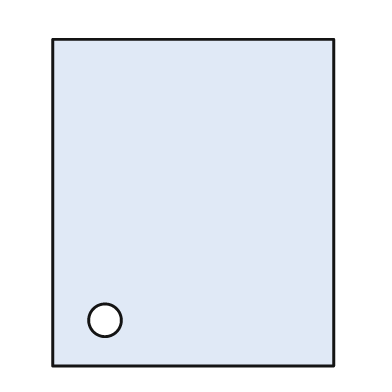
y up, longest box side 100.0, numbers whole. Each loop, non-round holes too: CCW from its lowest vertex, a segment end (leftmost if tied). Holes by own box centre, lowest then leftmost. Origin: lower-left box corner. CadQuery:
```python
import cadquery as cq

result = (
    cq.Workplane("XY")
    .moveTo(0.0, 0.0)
    .lineTo(86.0, 0.0)
    .lineTo(86.0, 100.0)
    .lineTo(0.0, 100.0)
    .close()
    .moveTo(16.0, 14.0)
    .circle(5.0)
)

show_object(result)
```